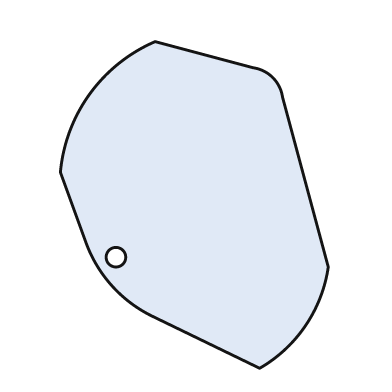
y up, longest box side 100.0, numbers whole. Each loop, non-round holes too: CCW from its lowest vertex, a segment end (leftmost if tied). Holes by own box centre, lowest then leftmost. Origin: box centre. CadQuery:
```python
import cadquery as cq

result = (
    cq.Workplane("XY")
    .moveTo(20.0, -50.0)
    .threePointArc((34.0, -37.0), (41.0, -19.0))
    .lineTo(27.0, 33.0)
    .threePointArc((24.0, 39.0), (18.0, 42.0))
    .lineTo(-12.0, 50.0)
    .threePointArc((-32.0, 34.0), (-41.0, 10.0))
    .lineTo(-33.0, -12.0)
    .threePointArc((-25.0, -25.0), (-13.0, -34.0))
    .close()
    .moveTo(-24.0, -16.0)
    .circle(3.0)
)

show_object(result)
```